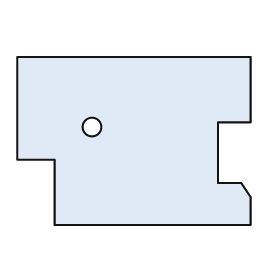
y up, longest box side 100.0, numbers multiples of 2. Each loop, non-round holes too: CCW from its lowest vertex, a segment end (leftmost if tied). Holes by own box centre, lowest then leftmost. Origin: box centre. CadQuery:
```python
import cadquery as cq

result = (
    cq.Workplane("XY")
    .moveTo(-34.0, -36.0)
    .lineTo(50.0, -36.0)
    .lineTo(50.0, -24.0)
    .lineTo(46.0, -18.0)
    .lineTo(36.0, -18.0)
    .lineTo(36.0, 8.0)
    .lineTo(50.0, 8.0)
    .lineTo(50.0, 36.0)
    .lineTo(-50.0, 36.0)
    .lineTo(-50.0, -8.0)
    .lineTo(-34.0, -8.0)
    .close()
    .moveTo(-18.0, 6.0)
    .circle(4.0)
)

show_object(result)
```